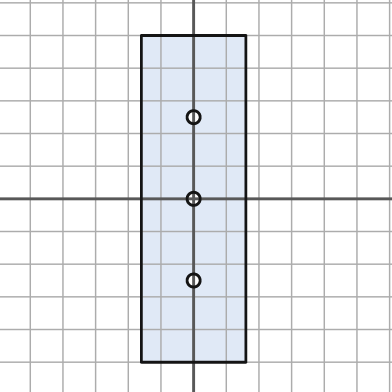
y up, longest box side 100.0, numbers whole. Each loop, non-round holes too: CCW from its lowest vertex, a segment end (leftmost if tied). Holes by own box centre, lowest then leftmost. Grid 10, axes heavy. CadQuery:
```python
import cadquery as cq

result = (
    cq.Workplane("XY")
    .moveTo(-16.0, -50.0)
    .lineTo(16.0, -50.0)
    .lineTo(16.0, 50.0)
    .lineTo(-16.0, 50.0)
    .close()
    .moveTo(0.0, -25.0)
    .circle(2.0)
    .moveTo(0.0, 0.0)
    .circle(2.0)
    .moveTo(0.0, 25.0)
    .circle(2.0)
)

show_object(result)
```